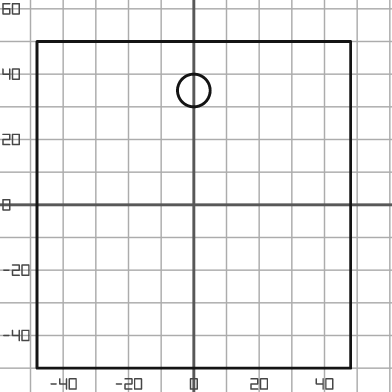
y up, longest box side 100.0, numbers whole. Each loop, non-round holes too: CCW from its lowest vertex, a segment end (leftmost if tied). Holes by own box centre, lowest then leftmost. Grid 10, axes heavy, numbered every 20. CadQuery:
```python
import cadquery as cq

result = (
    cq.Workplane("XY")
    .moveTo(-48.0, -50.0)
    .lineTo(48.0, -50.0)
    .lineTo(48.0, 50.0)
    .lineTo(-48.0, 50.0)
    .close()
    .moveTo(0.0, 35.0)
    .circle(5.0)
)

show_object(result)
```